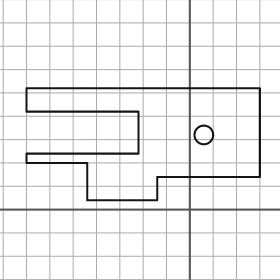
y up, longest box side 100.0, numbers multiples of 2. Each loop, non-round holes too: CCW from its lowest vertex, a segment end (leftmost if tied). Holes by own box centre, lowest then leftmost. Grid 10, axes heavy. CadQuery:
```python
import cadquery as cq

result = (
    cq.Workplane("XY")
    .moveTo(-44.0, 4.0)
    .lineTo(-14.0, 4.0)
    .lineTo(-14.0, 14.0)
    .lineTo(30.0, 14.0)
    .lineTo(30.0, 52.0)
    .lineTo(-70.0, 52.0)
    .lineTo(-70.0, 42.0)
    .lineTo(-22.0, 42.0)
    .lineTo(-22.0, 24.0)
    .lineTo(-70.0, 24.0)
    .lineTo(-70.0, 20.0)
    .lineTo(-44.0, 20.0)
    .close()
    .moveTo(6.0, 32.0)
    .circle(4.0)
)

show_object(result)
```